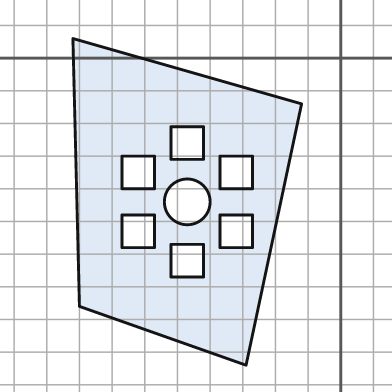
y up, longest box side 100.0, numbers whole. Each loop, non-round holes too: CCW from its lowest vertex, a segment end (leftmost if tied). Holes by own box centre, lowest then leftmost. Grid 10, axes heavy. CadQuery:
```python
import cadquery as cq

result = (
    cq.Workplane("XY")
    .moveTo(-29.0, -94.0)
    .lineTo(-12.0, -14.0)
    .lineTo(-82.0, 6.0)
    .lineTo(-80.0, -76.0)
    .close()
    .moveTo(-52.0, -67.0)
    .lineTo(-42.0, -67.0)
    .lineTo(-42.0, -57.0)
    .lineTo(-52.0, -57.0)
    .close()
    .moveTo(-67.0, -58.0)
    .lineTo(-57.0, -58.0)
    .lineTo(-57.0, -48.0)
    .lineTo(-67.0, -48.0)
    .close()
    .moveTo(-37.0, -58.0)
    .lineTo(-27.0, -58.0)
    .lineTo(-27.0, -48.0)
    .lineTo(-37.0, -48.0)
    .close()
    .moveTo(-47.0, -44.0)
    .circle(7.0)
    .moveTo(-67.0, -40.0)
    .lineTo(-57.0, -40.0)
    .lineTo(-57.0, -30.0)
    .lineTo(-67.0, -30.0)
    .close()
    .moveTo(-37.0, -40.0)
    .lineTo(-27.0, -40.0)
    .lineTo(-27.0, -30.0)
    .lineTo(-37.0, -30.0)
    .close()
    .moveTo(-52.0, -31.0)
    .lineTo(-42.0, -31.0)
    .lineTo(-42.0, -21.0)
    .lineTo(-52.0, -21.0)
    .close()
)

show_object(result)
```